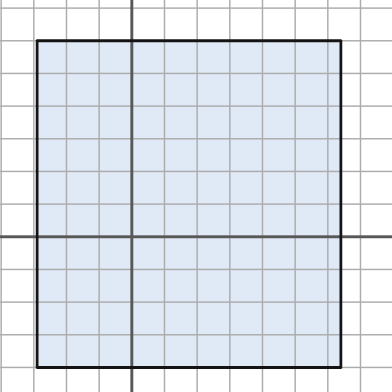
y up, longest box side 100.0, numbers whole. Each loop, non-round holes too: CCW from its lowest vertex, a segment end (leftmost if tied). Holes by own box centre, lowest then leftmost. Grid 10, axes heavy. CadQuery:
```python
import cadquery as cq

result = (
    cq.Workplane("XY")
    .moveTo(-29.0, -40.0)
    .lineTo(64.0, -40.0)
    .lineTo(64.0, 60.0)
    .lineTo(-29.0, 60.0)
    .close()
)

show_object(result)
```